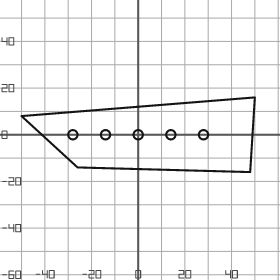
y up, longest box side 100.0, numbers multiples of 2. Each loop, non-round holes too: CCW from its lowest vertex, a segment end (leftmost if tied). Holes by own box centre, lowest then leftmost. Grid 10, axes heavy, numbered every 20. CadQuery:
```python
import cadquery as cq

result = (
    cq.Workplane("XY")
    .moveTo(48.0, -16.0)
    .lineTo(50.0, 16.0)
    .lineTo(-50.0, 8.0)
    .lineTo(-26.0, -14.0)
    .close()
    .moveTo(-28.0, 0.0)
    .circle(2.0)
    .moveTo(-14.0, 0.0)
    .circle(2.0)
    .moveTo(0.0, 0.0)
    .circle(2.0)
    .moveTo(14.0, 0.0)
    .circle(2.0)
    .moveTo(28.0, 0.0)
    .circle(2.0)
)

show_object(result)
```